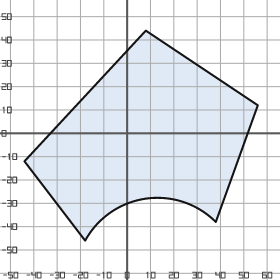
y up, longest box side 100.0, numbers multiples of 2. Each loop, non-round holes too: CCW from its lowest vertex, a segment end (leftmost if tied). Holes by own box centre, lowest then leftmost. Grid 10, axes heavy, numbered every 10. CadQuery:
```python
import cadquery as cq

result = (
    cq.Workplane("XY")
    .moveTo(-18.0, -46.0)
    .threePointArc((8.0, -28.0), (38.0, -38.0))
    .lineTo(56.0, 12.0)
    .lineTo(8.0, 44.0)
    .lineTo(-44.0, -12.0)
    .close()
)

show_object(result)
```